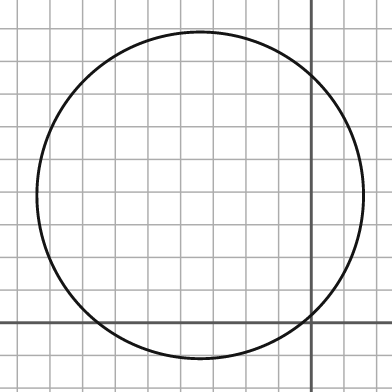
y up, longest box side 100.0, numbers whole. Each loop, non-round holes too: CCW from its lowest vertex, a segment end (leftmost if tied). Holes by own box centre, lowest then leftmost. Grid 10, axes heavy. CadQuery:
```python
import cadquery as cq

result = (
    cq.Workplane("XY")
    .moveTo(-34.0, 39.0)
    .circle(50.0)
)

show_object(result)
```